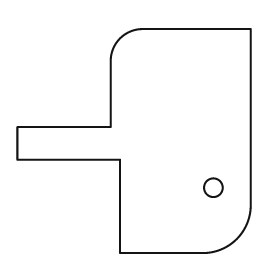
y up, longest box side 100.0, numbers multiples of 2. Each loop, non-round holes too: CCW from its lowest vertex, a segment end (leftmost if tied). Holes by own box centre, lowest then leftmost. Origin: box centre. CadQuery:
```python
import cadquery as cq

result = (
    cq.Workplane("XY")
    .moveTo(-6.0, -48.0)
    .lineTo(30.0, -48.0)
    .threePointArc((44.0, -42.0), (50.0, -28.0))
    .lineTo(50.0, 48.0)
    .lineTo(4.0, 48.0)
    .threePointArc((-6.0, 44.0), (-10.0, 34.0))
    .lineTo(-10.0, 6.0)
    .lineTo(-50.0, 6.0)
    .lineTo(-50.0, -8.0)
    .lineTo(-6.0, -8.0)
    .close()
    .moveTo(34.0, -20.0)
    .circle(4.0)
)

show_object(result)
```